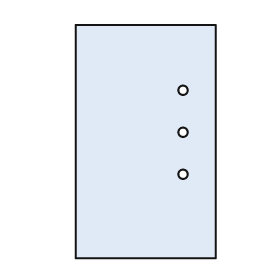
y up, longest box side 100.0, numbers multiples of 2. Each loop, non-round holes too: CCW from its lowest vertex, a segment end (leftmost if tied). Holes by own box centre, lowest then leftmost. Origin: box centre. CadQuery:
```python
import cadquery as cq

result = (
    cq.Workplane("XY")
    .moveTo(-30.0, -50.0)
    .lineTo(30.0, -50.0)
    .lineTo(30.0, 50.0)
    .lineTo(-30.0, 50.0)
    .close()
    .moveTo(16.0, -14.0)
    .circle(2.0)
    .moveTo(16.0, 4.0)
    .circle(2.0)
    .moveTo(16.0, 22.0)
    .circle(2.0)
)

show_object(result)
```